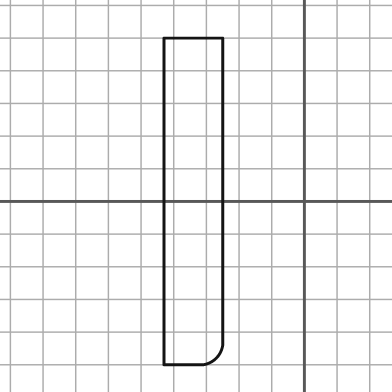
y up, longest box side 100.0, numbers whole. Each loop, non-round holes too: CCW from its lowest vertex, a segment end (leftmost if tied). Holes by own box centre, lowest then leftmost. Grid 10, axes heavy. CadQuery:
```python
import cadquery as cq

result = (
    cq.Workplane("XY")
    .moveTo(-43.0, -50.0)
    .lineTo(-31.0, -50.0)
    .threePointArc((-27.0, -48.0), (-25.0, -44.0))
    .lineTo(-25.0, 50.0)
    .lineTo(-43.0, 50.0)
    .close()
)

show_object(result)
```